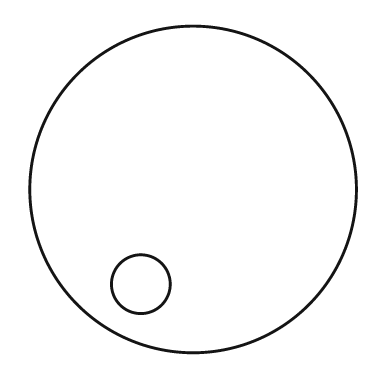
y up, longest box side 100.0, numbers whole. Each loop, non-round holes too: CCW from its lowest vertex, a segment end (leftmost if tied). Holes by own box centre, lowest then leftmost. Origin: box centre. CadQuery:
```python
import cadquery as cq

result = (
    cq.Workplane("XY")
    .moveTo(0.0, 0.0)
    .circle(50.0)
    .moveTo(-16.0, -29.0)
    .circle(9.0)
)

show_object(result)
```